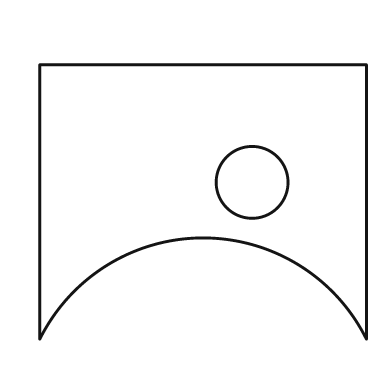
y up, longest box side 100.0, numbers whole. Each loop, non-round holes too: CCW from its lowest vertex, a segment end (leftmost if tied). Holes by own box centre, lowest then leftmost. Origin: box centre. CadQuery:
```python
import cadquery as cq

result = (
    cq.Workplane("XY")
    .moveTo(-50.0, -42.0)
    .threePointArc((0.0, -11.0), (50.0, -42.0))
    .lineTo(50.0, 42.0)
    .lineTo(-50.0, 42.0)
    .close()
    .moveTo(15.0, 6.0)
    .circle(11.0)
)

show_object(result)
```